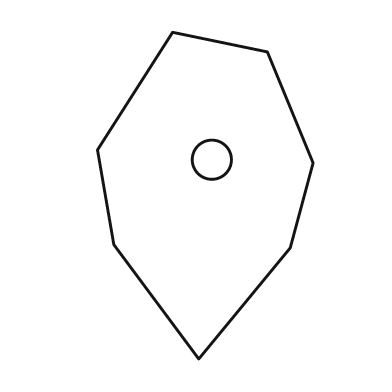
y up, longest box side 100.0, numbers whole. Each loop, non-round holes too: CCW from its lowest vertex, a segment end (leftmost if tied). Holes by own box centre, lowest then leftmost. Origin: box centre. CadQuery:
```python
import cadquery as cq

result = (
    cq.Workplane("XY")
    .moveTo(-2.0, -50.0)
    .lineTo(26.0, -16.0)
    .lineTo(33.0, 10.0)
    .lineTo(19.0, 44.0)
    .lineTo(-10.0, 50.0)
    .lineTo(-33.0, 14.0)
    .lineTo(-28.0, -15.0)
    .close()
    .moveTo(2.0, 11.0)
    .circle(6.0)
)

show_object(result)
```